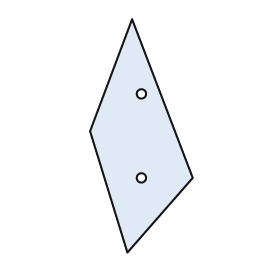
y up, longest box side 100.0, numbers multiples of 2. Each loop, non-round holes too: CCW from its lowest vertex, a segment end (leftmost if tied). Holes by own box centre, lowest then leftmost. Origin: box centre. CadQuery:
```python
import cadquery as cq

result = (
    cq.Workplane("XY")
    .moveTo(-6.0, -50.0)
    .lineTo(22.0, -18.0)
    .lineTo(-4.0, 50.0)
    .lineTo(-22.0, 2.0)
    .close()
    .moveTo(0.0, -18.0)
    .circle(2.0)
    .moveTo(0.0, 18.0)
    .circle(2.0)
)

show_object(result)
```